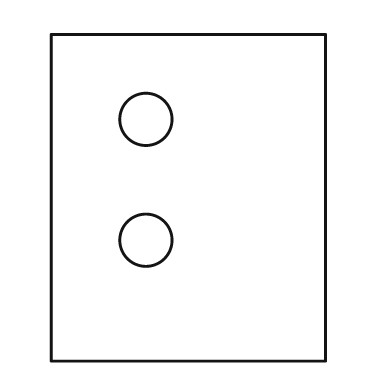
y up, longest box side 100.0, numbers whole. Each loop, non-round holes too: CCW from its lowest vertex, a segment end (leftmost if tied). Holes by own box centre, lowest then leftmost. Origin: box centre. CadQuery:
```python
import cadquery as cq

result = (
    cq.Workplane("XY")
    .moveTo(-42.0, -50.0)
    .lineTo(42.0, -50.0)
    .lineTo(42.0, 50.0)
    .lineTo(-42.0, 50.0)
    .close()
    .moveTo(-13.0, -13.0)
    .circle(8.0)
    .moveTo(-13.0, 24.0)
    .circle(8.0)
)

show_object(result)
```